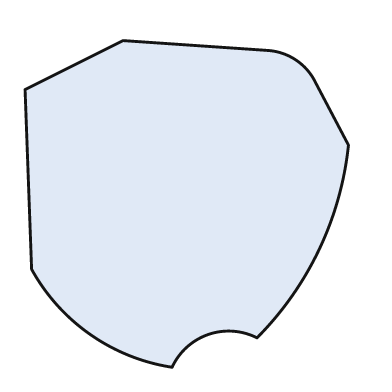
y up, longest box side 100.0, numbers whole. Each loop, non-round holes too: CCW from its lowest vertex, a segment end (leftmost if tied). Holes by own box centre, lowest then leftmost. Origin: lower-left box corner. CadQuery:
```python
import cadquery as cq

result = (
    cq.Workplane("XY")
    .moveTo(45.0, 0.0)
    .threePointArc((56.0, 10.0), (71.0, 9.0))
    .threePointArc((90.0, 36.0), (99.0, 68.0))
    .lineTo(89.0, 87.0)
    .threePointArc((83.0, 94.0), (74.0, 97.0))
    .lineTo(30.0, 100.0)
    .lineTo(0.0, 85.0)
    .lineTo(2.0, 30.0)
    .threePointArc((20.0, 10.0), (45.0, 0.0))
    .close()
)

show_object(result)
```